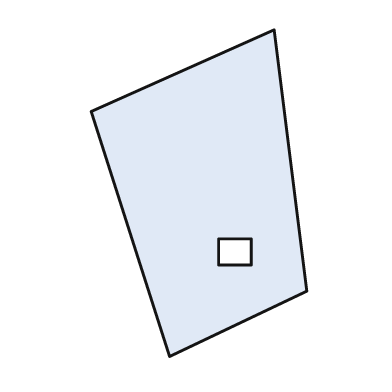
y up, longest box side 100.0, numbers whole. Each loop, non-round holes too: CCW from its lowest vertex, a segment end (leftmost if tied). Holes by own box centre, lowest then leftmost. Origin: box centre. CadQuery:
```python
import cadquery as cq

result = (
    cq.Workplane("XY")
    .moveTo(-9.0, -50.0)
    .lineTo(33.0, -30.0)
    .lineTo(23.0, 50.0)
    .lineTo(-33.0, 25.0)
    .close()
    .moveTo(6.0, -22.0)
    .lineTo(16.0, -22.0)
    .lineTo(16.0, -14.0)
    .lineTo(6.0, -14.0)
    .close()
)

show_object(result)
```